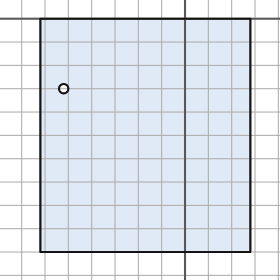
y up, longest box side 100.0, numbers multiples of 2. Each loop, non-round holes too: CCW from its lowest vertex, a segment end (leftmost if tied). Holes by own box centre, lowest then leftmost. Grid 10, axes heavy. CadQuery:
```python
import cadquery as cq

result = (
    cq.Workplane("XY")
    .moveTo(-62.0, -100.0)
    .lineTo(28.0, -100.0)
    .lineTo(28.0, 0.0)
    .lineTo(-62.0, 0.0)
    .close()
    .moveTo(-52.0, -30.0)
    .circle(2.0)
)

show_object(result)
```